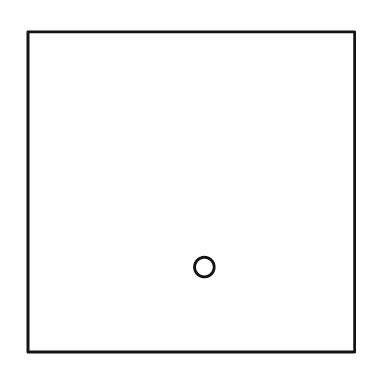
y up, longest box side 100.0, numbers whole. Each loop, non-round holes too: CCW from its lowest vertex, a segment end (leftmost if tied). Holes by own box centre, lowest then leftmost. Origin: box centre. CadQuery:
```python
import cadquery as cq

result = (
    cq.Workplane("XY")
    .moveTo(-50.0, -49.0)
    .lineTo(50.0, -49.0)
    .lineTo(50.0, 49.0)
    .lineTo(-50.0, 49.0)
    .close()
    .moveTo(4.0, -23.0)
    .circle(3.0)
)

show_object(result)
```